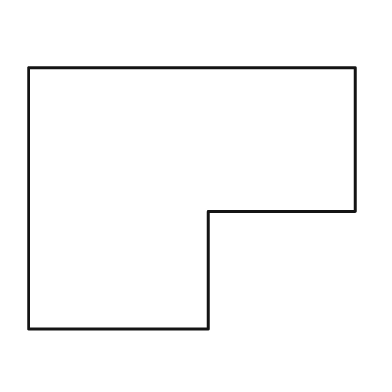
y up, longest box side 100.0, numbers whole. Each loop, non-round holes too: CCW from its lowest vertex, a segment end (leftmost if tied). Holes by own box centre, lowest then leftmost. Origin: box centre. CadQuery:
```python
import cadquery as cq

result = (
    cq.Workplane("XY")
    .moveTo(-50.0, -40.0)
    .lineTo(5.0, -40.0)
    .lineTo(5.0, -4.0)
    .lineTo(50.0, -4.0)
    .lineTo(50.0, 40.0)
    .lineTo(-50.0, 40.0)
    .close()
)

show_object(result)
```